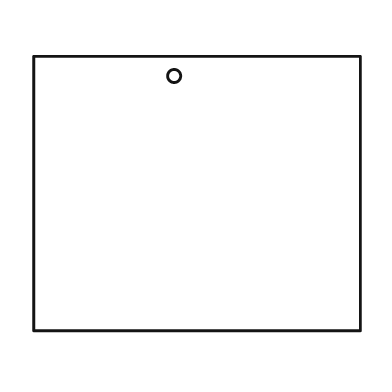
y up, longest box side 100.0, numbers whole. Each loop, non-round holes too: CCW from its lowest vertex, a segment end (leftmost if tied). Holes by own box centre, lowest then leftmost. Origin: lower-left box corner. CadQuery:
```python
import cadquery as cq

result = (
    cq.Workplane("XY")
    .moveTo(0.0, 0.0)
    .lineTo(100.0, 0.0)
    .lineTo(100.0, 84.0)
    .lineTo(0.0, 84.0)
    .close()
    .moveTo(43.0, 78.0)
    .circle(2.0)
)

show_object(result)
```